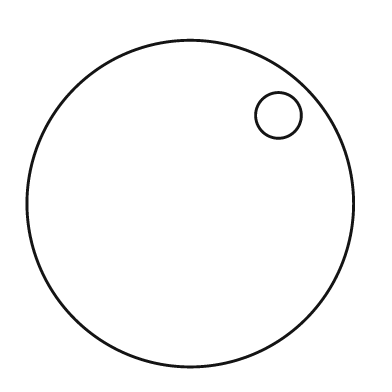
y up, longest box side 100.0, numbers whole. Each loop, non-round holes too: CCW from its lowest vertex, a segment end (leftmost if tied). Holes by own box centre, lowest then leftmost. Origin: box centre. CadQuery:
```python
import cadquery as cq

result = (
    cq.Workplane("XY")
    .moveTo(0.0, 0.0)
    .circle(50.0)
    .moveTo(27.0, 27.0)
    .circle(7.0)
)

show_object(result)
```